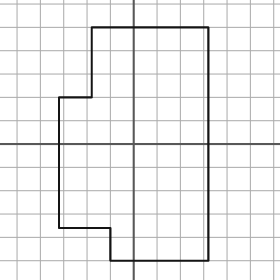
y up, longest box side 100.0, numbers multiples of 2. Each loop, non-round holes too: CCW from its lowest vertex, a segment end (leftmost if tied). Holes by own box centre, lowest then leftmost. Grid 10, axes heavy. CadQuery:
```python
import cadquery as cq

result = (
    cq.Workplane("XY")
    .moveTo(-10.0, -50.0)
    .lineTo(32.0, -50.0)
    .lineTo(32.0, 50.0)
    .lineTo(-18.0, 50.0)
    .lineTo(-18.0, 20.0)
    .lineTo(-32.0, 20.0)
    .lineTo(-32.0, -36.0)
    .lineTo(-10.0, -36.0)
    .close()
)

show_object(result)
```